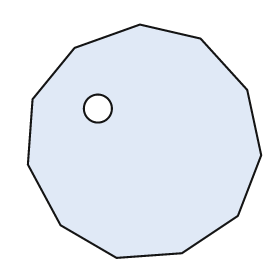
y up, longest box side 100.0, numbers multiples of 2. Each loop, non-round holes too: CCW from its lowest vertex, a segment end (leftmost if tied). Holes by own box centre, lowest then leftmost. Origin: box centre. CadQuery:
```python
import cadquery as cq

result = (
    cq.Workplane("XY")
    .moveTo(-12.0, -50.0)
    .lineTo(16.0, -48.0)
    .lineTo(40.0, -32.0)
    .lineTo(50.0, -6.0)
    .lineTo(44.0, 22.0)
    .lineTo(24.0, 44.0)
    .lineTo(-2.0, 50.0)
    .lineTo(-30.0, 40.0)
    .lineTo(-48.0, 18.0)
    .lineTo(-50.0, -10.0)
    .lineTo(-36.0, -36.0)
    .close()
    .moveTo(-20.0, 14.0)
    .circle(6.0)
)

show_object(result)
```